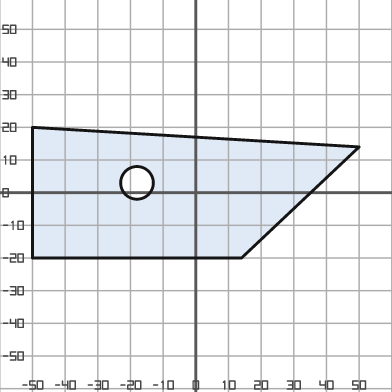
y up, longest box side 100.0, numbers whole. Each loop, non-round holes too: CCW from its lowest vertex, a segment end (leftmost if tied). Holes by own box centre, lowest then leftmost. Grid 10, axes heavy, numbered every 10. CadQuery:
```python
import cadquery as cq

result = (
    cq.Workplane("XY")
    .moveTo(-50.0, -20.0)
    .lineTo(14.0, -20.0)
    .lineTo(50.0, 14.0)
    .lineTo(-50.0, 20.0)
    .close()
    .moveTo(-18.0, 3.0)
    .circle(5.0)
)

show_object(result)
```